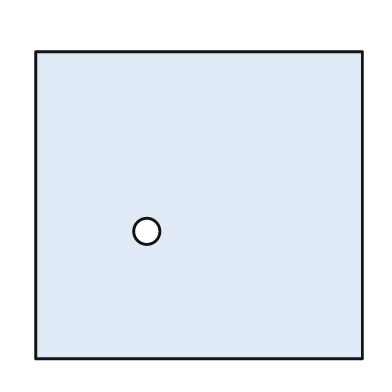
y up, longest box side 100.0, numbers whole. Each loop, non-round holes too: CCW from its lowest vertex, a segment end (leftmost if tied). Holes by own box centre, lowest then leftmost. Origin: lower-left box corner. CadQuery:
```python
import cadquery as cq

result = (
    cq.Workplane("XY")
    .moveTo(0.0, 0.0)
    .lineTo(100.0, 0.0)
    .lineTo(100.0, 94.0)
    .lineTo(0.0, 94.0)
    .close()
    .moveTo(34.0, 39.0)
    .circle(4.0)
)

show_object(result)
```